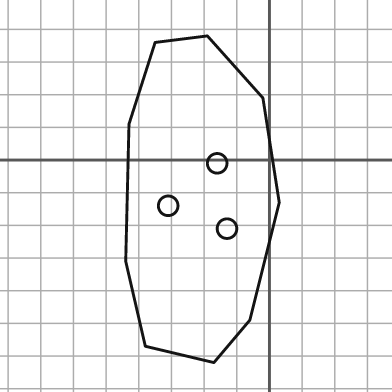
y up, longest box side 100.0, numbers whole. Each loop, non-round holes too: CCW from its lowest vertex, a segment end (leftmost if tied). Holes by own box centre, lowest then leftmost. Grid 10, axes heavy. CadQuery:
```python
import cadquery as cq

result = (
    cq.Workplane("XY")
    .moveTo(-17.0, -62.0)
    .lineTo(-6.0, -49.0)
    .lineTo(3.0, -13.0)
    .lineTo(-2.0, 19.0)
    .lineTo(-19.0, 38.0)
    .lineTo(-35.0, 36.0)
    .lineTo(-43.0, 11.0)
    .lineTo(-44.0, -31.0)
    .lineTo(-38.0, -57.0)
    .close()
    .moveTo(-13.0, -21.0)
    .circle(3.0)
    .moveTo(-31.0, -14.0)
    .circle(3.0)
    .moveTo(-16.0, -1.0)
    .circle(3.0)
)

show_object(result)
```